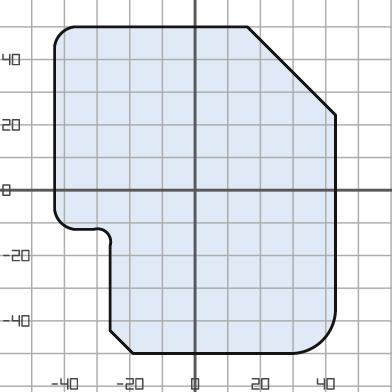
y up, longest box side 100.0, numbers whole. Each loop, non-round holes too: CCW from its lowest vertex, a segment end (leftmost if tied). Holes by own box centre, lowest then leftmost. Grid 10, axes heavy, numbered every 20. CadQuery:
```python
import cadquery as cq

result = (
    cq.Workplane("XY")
    .moveTo(-19.0, -50.0)
    .lineTo(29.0, -50.0)
    .threePointArc((39.0, -46.0), (43.0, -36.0))
    .lineTo(43.0, 23.0)
    .lineTo(16.0, 50.0)
    .lineTo(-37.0, 50.0)
    .threePointArc((-41.0, 48.0), (-43.0, 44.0))
    .lineTo(-43.0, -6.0)
    .threePointArc((-41.0, -10.0), (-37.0, -12.0))
    .lineTo(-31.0, -12.0)
    .threePointArc((-27.0, -13.0), (-26.0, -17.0))
    .lineTo(-26.0, -43.0)
    .close()
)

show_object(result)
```